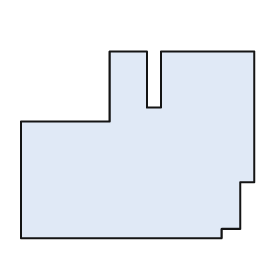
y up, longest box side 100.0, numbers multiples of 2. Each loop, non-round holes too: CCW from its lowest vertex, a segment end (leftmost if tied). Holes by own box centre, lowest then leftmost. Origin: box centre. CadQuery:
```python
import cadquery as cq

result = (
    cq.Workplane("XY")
    .moveTo(-50.0, -40.0)
    .lineTo(36.0, -40.0)
    .lineTo(36.0, -36.0)
    .lineTo(44.0, -36.0)
    .lineTo(44.0, -16.0)
    .lineTo(50.0, -16.0)
    .lineTo(50.0, 40.0)
    .lineTo(10.0, 40.0)
    .lineTo(10.0, 16.0)
    .lineTo(4.0, 16.0)
    .lineTo(4.0, 40.0)
    .lineTo(-12.0, 40.0)
    .lineTo(-12.0, 10.0)
    .lineTo(-50.0, 10.0)
    .close()
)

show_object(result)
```